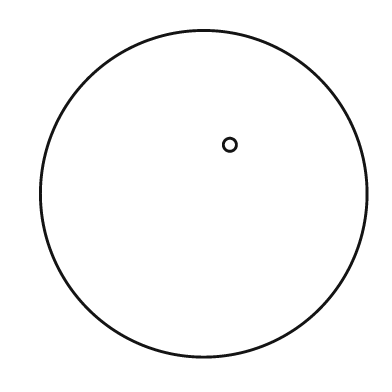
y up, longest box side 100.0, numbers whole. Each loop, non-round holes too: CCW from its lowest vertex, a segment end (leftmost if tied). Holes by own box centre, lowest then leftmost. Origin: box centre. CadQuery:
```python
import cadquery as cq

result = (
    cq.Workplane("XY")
    .moveTo(0.0, 0.0)
    .circle(50.0)
    .moveTo(8.0, 15.0)
    .circle(2.0)
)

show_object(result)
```